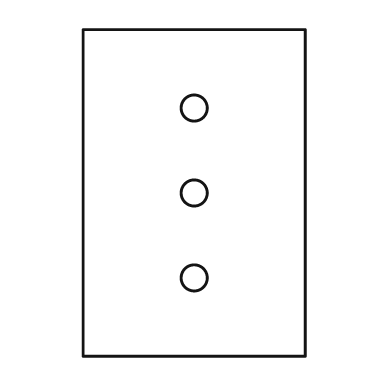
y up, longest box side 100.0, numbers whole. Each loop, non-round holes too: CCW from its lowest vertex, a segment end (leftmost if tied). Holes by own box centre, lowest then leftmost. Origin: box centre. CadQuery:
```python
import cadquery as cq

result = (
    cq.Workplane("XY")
    .moveTo(-34.0, -50.0)
    .lineTo(34.0, -50.0)
    .lineTo(34.0, 50.0)
    .lineTo(-34.0, 50.0)
    .close()
    .moveTo(0.0, -26.0)
    .circle(4.0)
    .moveTo(0.0, 0.0)
    .circle(4.0)
    .moveTo(0.0, 26.0)
    .circle(4.0)
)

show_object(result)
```